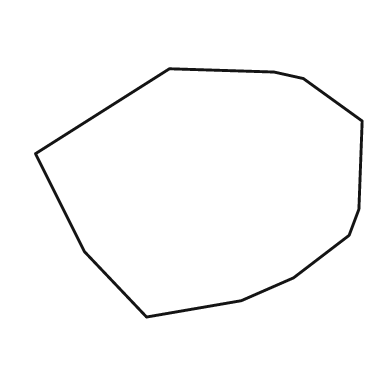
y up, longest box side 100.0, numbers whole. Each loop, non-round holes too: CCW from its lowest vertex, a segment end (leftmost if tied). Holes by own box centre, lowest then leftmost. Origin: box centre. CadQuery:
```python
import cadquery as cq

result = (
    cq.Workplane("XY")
    .moveTo(-16.0, -38.0)
    .lineTo(13.0, -33.0)
    .lineTo(29.0, -26.0)
    .lineTo(46.0, -13.0)
    .lineTo(49.0, -5.0)
    .lineTo(50.0, 22.0)
    .lineTo(32.0, 35.0)
    .lineTo(23.0, 37.0)
    .lineTo(-9.0, 38.0)
    .lineTo(-50.0, 12.0)
    .lineTo(-35.0, -18.0)
    .close()
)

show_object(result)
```